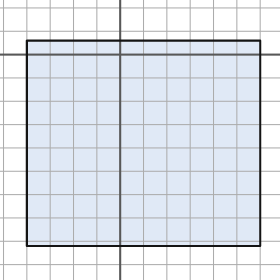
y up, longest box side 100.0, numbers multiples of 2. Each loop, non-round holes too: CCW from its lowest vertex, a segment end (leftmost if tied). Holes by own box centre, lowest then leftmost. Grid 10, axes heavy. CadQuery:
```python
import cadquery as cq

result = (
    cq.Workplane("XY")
    .moveTo(-40.0, -82.0)
    .lineTo(60.0, -82.0)
    .lineTo(60.0, 6.0)
    .lineTo(-40.0, 6.0)
    .close()
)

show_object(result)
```